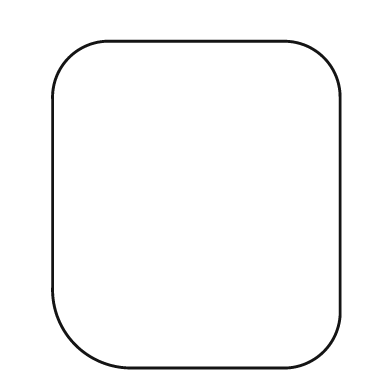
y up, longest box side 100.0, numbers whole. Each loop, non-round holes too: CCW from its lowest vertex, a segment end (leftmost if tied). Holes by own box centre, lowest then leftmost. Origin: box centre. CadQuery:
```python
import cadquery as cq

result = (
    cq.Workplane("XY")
    .moveTo(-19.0, -50.0)
    .lineTo(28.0, -50.0)
    .threePointArc((39.0, -45.0), (44.0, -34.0))
    .lineTo(44.0, 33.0)
    .threePointArc((39.0, 45.0), (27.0, 50.0))
    .lineTo(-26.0, 50.0)
    .threePointArc((-39.0, 45.0), (-44.0, 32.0))
    .lineTo(-44.0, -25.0)
    .threePointArc((-37.0, -43.0), (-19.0, -50.0))
    .close()
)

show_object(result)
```